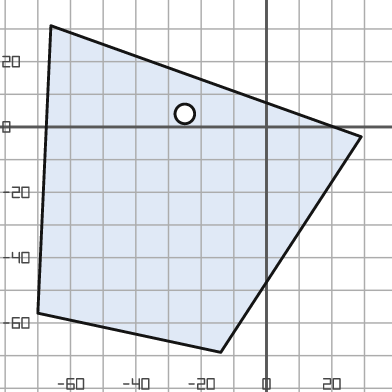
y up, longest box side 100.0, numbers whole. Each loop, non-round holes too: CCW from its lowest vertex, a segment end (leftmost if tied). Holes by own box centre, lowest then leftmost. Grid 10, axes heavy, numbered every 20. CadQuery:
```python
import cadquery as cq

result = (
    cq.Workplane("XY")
    .moveTo(-14.0, -69.0)
    .lineTo(29.0, -3.0)
    .lineTo(-66.0, 31.0)
    .lineTo(-70.0, -57.0)
    .close()
    .moveTo(-25.0, 4.0)
    .circle(3.0)
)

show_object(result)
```